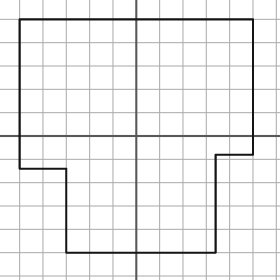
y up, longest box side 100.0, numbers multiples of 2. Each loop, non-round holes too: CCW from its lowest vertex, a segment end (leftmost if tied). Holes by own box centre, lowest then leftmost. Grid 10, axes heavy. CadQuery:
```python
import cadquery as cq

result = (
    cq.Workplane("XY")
    .moveTo(-30.0, -50.0)
    .lineTo(34.0, -50.0)
    .lineTo(34.0, -8.0)
    .lineTo(50.0, -8.0)
    .lineTo(50.0, 50.0)
    .lineTo(-50.0, 50.0)
    .lineTo(-50.0, -14.0)
    .lineTo(-30.0, -14.0)
    .close()
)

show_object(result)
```